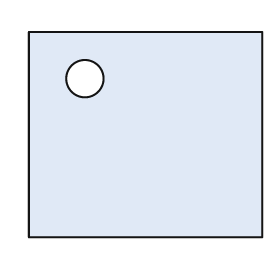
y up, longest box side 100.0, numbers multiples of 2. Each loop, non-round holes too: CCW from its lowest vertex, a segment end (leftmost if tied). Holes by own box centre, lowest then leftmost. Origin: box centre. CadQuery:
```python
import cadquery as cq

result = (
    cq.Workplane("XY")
    .moveTo(-50.0, -44.0)
    .lineTo(50.0, -44.0)
    .lineTo(50.0, 44.0)
    .lineTo(-50.0, 44.0)
    .close()
    .moveTo(-26.0, 24.0)
    .circle(8.0)
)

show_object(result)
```